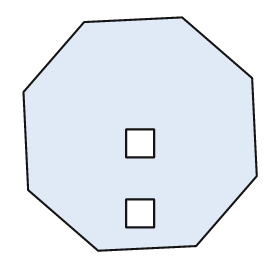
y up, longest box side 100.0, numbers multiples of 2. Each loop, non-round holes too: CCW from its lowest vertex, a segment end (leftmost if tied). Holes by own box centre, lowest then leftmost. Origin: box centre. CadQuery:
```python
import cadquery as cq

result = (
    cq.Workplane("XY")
    .moveTo(-18.0, -50.0)
    .lineTo(24.0, -48.0)
    .lineTo(50.0, -18.0)
    .lineTo(48.0, 24.0)
    .lineTo(18.0, 50.0)
    .lineTo(-24.0, 48.0)
    .lineTo(-50.0, 18.0)
    .lineTo(-48.0, -24.0)
    .close()
    .moveTo(-6.0, -40.0)
    .lineTo(6.0, -40.0)
    .lineTo(6.0, -28.0)
    .lineTo(-6.0, -28.0)
    .close()
    .moveTo(-6.0, -10.0)
    .lineTo(6.0, -10.0)
    .lineTo(6.0, 2.0)
    .lineTo(-6.0, 2.0)
    .close()
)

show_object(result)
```